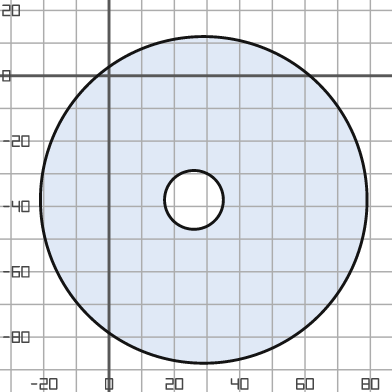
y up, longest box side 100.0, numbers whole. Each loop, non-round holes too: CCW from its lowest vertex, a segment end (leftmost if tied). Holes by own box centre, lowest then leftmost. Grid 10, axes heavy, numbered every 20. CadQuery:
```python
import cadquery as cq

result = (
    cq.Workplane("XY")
    .moveTo(29.0, -38.0)
    .circle(50.0)
    .moveTo(26.0, -38.0)
    .circle(9.0)
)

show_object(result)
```